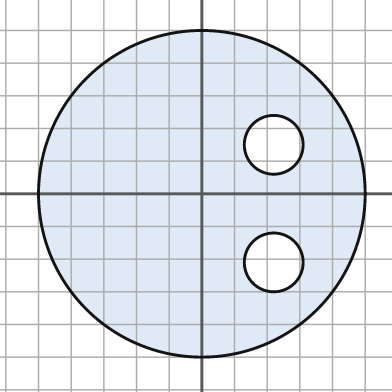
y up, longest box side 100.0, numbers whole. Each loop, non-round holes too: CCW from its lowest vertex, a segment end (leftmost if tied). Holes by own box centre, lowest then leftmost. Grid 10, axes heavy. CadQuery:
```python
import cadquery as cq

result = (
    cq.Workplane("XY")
    .moveTo(0.0, 0.0)
    .circle(50.0)
    .moveTo(22.0, -21.0)
    .circle(9.0)
    .moveTo(22.0, 15.0)
    .circle(9.0)
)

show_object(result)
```